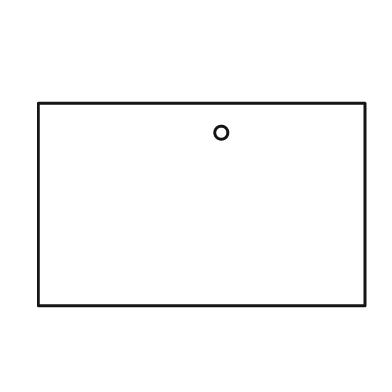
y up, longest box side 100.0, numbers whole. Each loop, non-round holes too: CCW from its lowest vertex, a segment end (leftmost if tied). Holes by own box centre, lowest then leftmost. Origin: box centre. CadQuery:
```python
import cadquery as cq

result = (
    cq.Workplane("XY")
    .moveTo(-50.0, -31.0)
    .lineTo(50.0, -31.0)
    .lineTo(50.0, 31.0)
    .lineTo(-50.0, 31.0)
    .close()
    .moveTo(6.0, 22.0)
    .circle(2.0)
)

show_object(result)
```